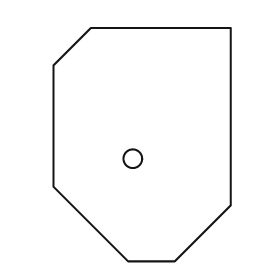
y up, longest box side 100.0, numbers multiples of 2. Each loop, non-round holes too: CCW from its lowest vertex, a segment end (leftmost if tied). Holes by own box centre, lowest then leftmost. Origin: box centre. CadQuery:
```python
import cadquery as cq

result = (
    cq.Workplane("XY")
    .moveTo(-6.0, -50.0)
    .lineTo(14.0, -50.0)
    .lineTo(38.0, -26.0)
    .lineTo(38.0, 50.0)
    .lineTo(-22.0, 50.0)
    .lineTo(-38.0, 34.0)
    .lineTo(-38.0, -18.0)
    .close()
    .moveTo(-4.0, -6.0)
    .circle(4.0)
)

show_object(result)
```